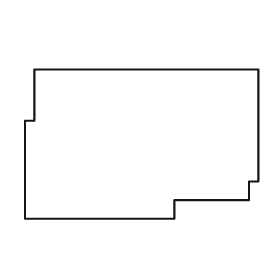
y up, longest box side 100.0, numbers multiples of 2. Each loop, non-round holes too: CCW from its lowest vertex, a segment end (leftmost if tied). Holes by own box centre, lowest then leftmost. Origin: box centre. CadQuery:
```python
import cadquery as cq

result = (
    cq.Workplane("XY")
    .moveTo(-50.0, -32.0)
    .lineTo(14.0, -32.0)
    .lineTo(14.0, -24.0)
    .lineTo(46.0, -24.0)
    .lineTo(46.0, -16.0)
    .lineTo(50.0, -16.0)
    .lineTo(50.0, 32.0)
    .lineTo(-46.0, 32.0)
    .lineTo(-46.0, 10.0)
    .lineTo(-50.0, 10.0)
    .close()
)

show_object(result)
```